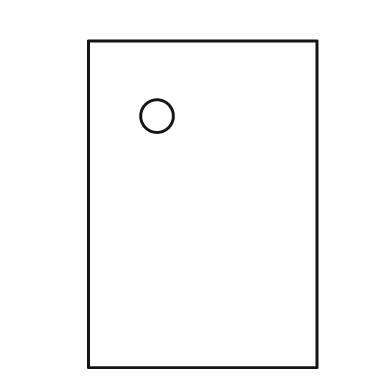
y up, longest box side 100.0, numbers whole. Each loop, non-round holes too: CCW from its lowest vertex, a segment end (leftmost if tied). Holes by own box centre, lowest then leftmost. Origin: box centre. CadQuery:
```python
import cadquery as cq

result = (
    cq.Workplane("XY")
    .moveTo(-35.0, -50.0)
    .lineTo(35.0, -50.0)
    .lineTo(35.0, 50.0)
    .lineTo(-35.0, 50.0)
    .close()
    .moveTo(-14.0, 27.0)
    .circle(5.0)
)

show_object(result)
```